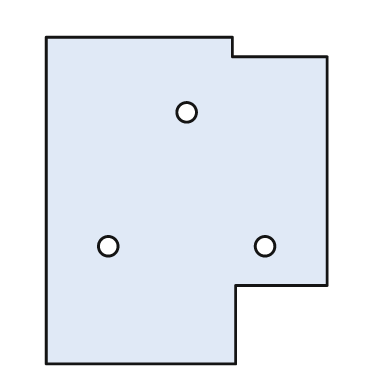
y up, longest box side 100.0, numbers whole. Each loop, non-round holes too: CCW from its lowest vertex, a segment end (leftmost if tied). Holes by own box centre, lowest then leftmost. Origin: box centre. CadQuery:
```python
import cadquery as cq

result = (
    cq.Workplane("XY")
    .moveTo(-43.0, -50.0)
    .lineTo(15.0, -50.0)
    .lineTo(15.0, -26.0)
    .lineTo(43.0, -26.0)
    .lineTo(43.0, 44.0)
    .lineTo(14.0, 44.0)
    .lineTo(14.0, 50.0)
    .lineTo(-43.0, 50.0)
    .close()
    .moveTo(-24.0, -14.0)
    .circle(3.0)
    .moveTo(24.0, -14.0)
    .circle(3.0)
    .moveTo(0.0, 27.0)
    .circle(3.0)
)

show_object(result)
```